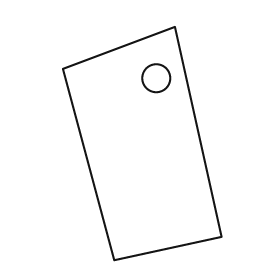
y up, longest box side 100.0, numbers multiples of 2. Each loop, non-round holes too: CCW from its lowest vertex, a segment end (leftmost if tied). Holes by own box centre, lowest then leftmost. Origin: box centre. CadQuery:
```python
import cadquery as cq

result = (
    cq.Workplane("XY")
    .moveTo(-12.0, -50.0)
    .lineTo(34.0, -40.0)
    .lineTo(14.0, 50.0)
    .lineTo(-34.0, 32.0)
    .close()
    .moveTo(6.0, 28.0)
    .circle(6.0)
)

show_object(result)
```